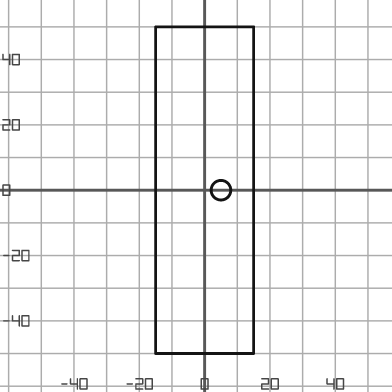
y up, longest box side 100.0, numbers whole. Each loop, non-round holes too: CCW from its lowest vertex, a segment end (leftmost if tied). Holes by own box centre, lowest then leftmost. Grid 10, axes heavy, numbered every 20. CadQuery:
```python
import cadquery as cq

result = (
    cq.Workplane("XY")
    .moveTo(-15.0, -50.0)
    .lineTo(15.0, -50.0)
    .lineTo(15.0, 50.0)
    .lineTo(-15.0, 50.0)
    .close()
    .moveTo(5.0, 0.0)
    .circle(3.0)
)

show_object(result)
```